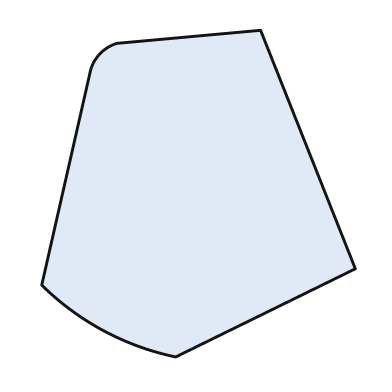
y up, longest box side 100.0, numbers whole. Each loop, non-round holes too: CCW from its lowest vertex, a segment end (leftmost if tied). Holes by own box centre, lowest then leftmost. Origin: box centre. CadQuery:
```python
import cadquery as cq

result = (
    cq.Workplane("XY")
    .moveTo(-7.0, -50.0)
    .lineTo(48.0, -23.0)
    .lineTo(19.0, 50.0)
    .lineTo(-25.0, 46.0)
    .threePointArc((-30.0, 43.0), (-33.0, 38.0))
    .lineTo(-48.0, -28.0)
    .threePointArc((-29.0, -42.0), (-7.0, -50.0))
    .close()
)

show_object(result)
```